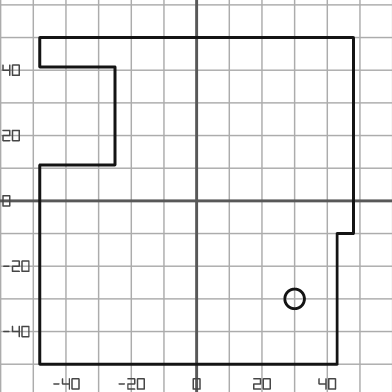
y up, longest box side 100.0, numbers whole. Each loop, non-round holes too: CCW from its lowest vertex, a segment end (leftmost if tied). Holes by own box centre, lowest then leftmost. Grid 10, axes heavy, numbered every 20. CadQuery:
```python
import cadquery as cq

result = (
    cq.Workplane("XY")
    .moveTo(-48.0, -50.0)
    .lineTo(43.0, -50.0)
    .lineTo(43.0, -10.0)
    .lineTo(48.0, -10.0)
    .lineTo(48.0, 50.0)
    .lineTo(-48.0, 50.0)
    .lineTo(-48.0, 41.0)
    .lineTo(-25.0, 41.0)
    .lineTo(-25.0, 11.0)
    .lineTo(-48.0, 11.0)
    .close()
    .moveTo(30.0, -30.0)
    .circle(3.0)
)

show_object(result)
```